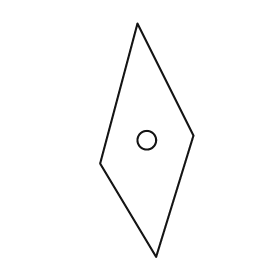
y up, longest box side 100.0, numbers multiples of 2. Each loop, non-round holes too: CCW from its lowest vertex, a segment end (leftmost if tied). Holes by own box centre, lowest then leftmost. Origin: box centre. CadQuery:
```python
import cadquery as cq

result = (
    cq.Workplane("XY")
    .moveTo(4.0, -50.0)
    .lineTo(20.0, 2.0)
    .lineTo(-4.0, 50.0)
    .lineTo(-20.0, -10.0)
    .close()
    .moveTo(0.0, 0.0)
    .circle(4.0)
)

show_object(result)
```